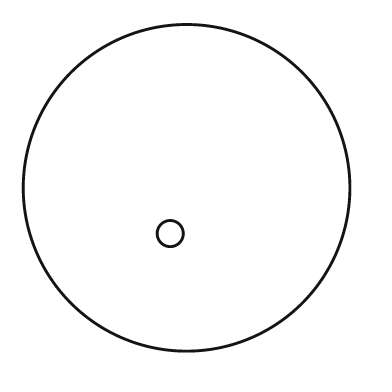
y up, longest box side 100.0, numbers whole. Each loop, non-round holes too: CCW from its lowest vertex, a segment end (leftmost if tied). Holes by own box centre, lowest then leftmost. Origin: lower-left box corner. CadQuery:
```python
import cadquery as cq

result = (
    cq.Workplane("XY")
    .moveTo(50.0, 50.0)
    .circle(50.0)
    .moveTo(45.0, 36.0)
    .circle(4.0)
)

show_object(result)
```